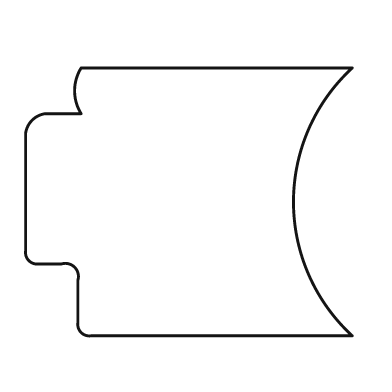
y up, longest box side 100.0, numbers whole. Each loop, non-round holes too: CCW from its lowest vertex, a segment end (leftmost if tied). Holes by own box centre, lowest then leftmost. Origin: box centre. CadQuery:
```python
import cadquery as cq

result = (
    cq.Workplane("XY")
    .moveTo(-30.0, -41.0)
    .lineTo(50.0, -41.0)
    .threePointArc((32.0, 0.0), (50.0, 41.0))
    .lineTo(-33.0, 41.0)
    .threePointArc((-35.0, 34.0), (-33.0, 27.0))
    .lineTo(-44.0, 27.0)
    .threePointArc((-48.0, 25.0), (-50.0, 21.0))
    .lineTo(-50.0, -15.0)
    .threePointArc((-49.0, -18.0), (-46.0, -19.0))
    .lineTo(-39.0, -19.0)
    .threePointArc((-35.0, -20.0), (-34.0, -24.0))
    .lineTo(-34.0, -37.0)
    .threePointArc((-33.0, -40.0), (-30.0, -41.0))
    .close()
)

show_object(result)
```